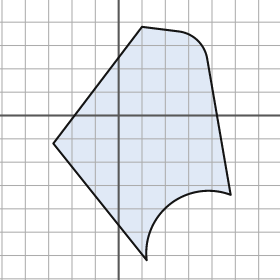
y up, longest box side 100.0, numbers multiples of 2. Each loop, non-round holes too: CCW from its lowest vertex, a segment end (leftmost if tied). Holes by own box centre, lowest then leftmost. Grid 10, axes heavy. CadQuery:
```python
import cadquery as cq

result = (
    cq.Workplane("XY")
    .moveTo(12.0, -62.0)
    .threePointArc((22.0, -38.0), (48.0, -34.0))
    .lineTo(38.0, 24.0)
    .threePointArc((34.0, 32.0), (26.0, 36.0))
    .lineTo(10.0, 38.0)
    .lineTo(-28.0, -12.0)
    .close()
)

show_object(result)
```